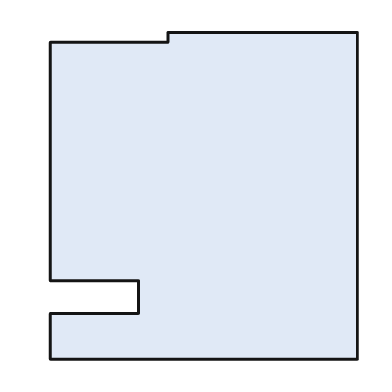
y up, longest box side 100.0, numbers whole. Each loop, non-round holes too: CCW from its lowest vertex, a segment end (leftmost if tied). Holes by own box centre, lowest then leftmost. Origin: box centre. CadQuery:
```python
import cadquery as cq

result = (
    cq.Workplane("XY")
    .moveTo(-47.0, -50.0)
    .lineTo(47.0, -50.0)
    .lineTo(47.0, 50.0)
    .lineTo(-11.0, 50.0)
    .lineTo(-11.0, 47.0)
    .lineTo(-47.0, 47.0)
    .lineTo(-47.0, -26.0)
    .lineTo(-20.0, -26.0)
    .lineTo(-20.0, -36.0)
    .lineTo(-47.0, -36.0)
    .close()
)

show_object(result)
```